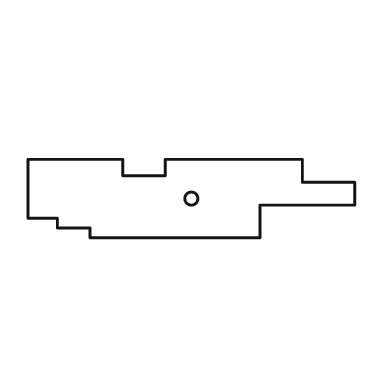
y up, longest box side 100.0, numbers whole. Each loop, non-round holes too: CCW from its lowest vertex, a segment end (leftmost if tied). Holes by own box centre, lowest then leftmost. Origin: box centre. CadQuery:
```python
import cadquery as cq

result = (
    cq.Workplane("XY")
    .moveTo(-31.0, -12.0)
    .lineTo(21.0, -12.0)
    .lineTo(21.0, -2.0)
    .lineTo(50.0, -2.0)
    .lineTo(50.0, 5.0)
    .lineTo(34.0, 5.0)
    .lineTo(34.0, 12.0)
    .lineTo(-8.0, 12.0)
    .lineTo(-8.0, 7.0)
    .lineTo(-21.0, 7.0)
    .lineTo(-21.0, 12.0)
    .lineTo(-50.0, 12.0)
    .lineTo(-50.0, -6.0)
    .lineTo(-41.0, -6.0)
    .lineTo(-41.0, -9.0)
    .lineTo(-31.0, -9.0)
    .close()
    .moveTo(0.0, 0.0)
    .circle(2.0)
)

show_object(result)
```